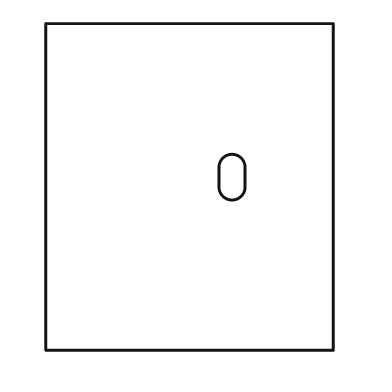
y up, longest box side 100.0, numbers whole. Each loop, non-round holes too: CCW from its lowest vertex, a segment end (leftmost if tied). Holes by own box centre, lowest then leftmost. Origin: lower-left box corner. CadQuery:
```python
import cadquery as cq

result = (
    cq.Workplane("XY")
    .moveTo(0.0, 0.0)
    .lineTo(88.0, 0.0)
    .lineTo(88.0, 100.0)
    .lineTo(0.0, 100.0)
    .close()
    .moveTo(53.0, 50.0)
    .threePointArc((57.0, 46.0), (61.0, 50.0))
    .lineTo(61.0, 56.0)
    .threePointArc((57.0, 60.0), (53.0, 56.0))
    .close()
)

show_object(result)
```